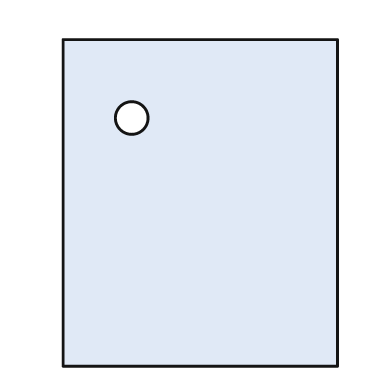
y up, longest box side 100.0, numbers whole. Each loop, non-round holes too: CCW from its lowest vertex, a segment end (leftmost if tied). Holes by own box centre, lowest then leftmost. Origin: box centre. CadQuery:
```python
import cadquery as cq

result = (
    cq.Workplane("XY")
    .moveTo(-42.0, -50.0)
    .lineTo(42.0, -50.0)
    .lineTo(42.0, 50.0)
    .lineTo(-42.0, 50.0)
    .close()
    .moveTo(-21.0, 26.0)
    .circle(5.0)
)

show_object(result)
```